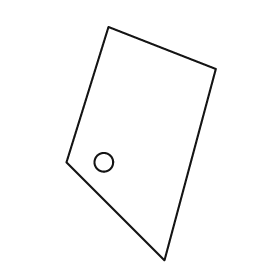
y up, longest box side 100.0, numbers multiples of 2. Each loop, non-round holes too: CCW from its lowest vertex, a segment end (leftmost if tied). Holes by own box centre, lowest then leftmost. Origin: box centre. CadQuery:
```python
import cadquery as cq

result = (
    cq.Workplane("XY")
    .moveTo(10.0, -50.0)
    .lineTo(32.0, 32.0)
    .lineTo(-14.0, 50.0)
    .lineTo(-32.0, -8.0)
    .close()
    .moveTo(-16.0, -8.0)
    .circle(4.0)
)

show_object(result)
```